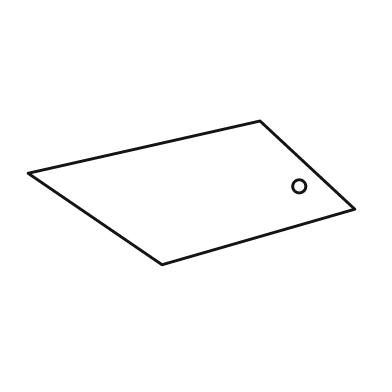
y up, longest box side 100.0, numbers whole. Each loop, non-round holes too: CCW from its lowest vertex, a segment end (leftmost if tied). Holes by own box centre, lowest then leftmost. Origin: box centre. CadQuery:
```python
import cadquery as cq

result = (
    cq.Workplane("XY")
    .moveTo(-9.0, -22.0)
    .lineTo(50.0, -5.0)
    .lineTo(21.0, 22.0)
    .lineTo(-50.0, 6.0)
    .close()
    .moveTo(33.0, 2.0)
    .circle(2.0)
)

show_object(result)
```